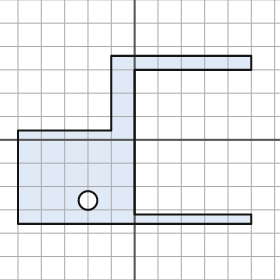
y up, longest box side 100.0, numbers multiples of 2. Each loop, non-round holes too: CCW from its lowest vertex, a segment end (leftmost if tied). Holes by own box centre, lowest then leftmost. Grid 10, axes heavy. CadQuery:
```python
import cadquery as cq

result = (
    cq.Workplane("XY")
    .moveTo(-50.0, -36.0)
    .lineTo(50.0, -36.0)
    .lineTo(50.0, -32.0)
    .lineTo(0.0, -32.0)
    .lineTo(0.0, 30.0)
    .lineTo(50.0, 30.0)
    .lineTo(50.0, 36.0)
    .lineTo(-10.0, 36.0)
    .lineTo(-10.0, 4.0)
    .lineTo(-50.0, 4.0)
    .close()
    .moveTo(-20.0, -26.0)
    .circle(4.0)
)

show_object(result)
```